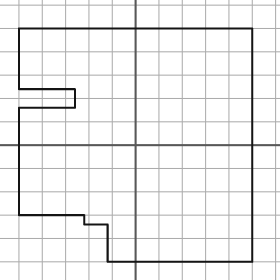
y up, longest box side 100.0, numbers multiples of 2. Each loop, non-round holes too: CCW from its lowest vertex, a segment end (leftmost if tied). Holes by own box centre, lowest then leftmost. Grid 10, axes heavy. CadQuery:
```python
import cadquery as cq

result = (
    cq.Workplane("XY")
    .moveTo(-12.0, -50.0)
    .lineTo(50.0, -50.0)
    .lineTo(50.0, 50.0)
    .lineTo(-50.0, 50.0)
    .lineTo(-50.0, 24.0)
    .lineTo(-26.0, 24.0)
    .lineTo(-26.0, 16.0)
    .lineTo(-50.0, 16.0)
    .lineTo(-50.0, -30.0)
    .lineTo(-22.0, -30.0)
    .lineTo(-22.0, -34.0)
    .lineTo(-12.0, -34.0)
    .close()
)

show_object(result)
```